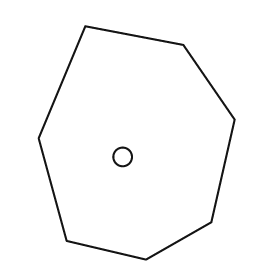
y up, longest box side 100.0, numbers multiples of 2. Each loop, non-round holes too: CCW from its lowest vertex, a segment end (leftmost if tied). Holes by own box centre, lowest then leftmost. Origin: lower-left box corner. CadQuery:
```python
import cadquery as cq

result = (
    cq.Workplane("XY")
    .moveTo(46.0, 0.0)
    .lineTo(74.0, 16.0)
    .lineTo(84.0, 60.0)
    .lineTo(62.0, 92.0)
    .lineTo(20.0, 100.0)
    .lineTo(0.0, 52.0)
    .lineTo(12.0, 8.0)
    .close()
    .moveTo(36.0, 44.0)
    .circle(4.0)
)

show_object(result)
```